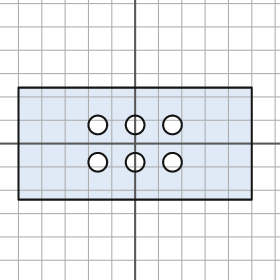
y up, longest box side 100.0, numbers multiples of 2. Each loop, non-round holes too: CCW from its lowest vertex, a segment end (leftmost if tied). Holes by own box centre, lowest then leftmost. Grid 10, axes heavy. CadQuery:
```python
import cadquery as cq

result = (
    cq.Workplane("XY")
    .moveTo(-50.0, -24.0)
    .lineTo(50.0, -24.0)
    .lineTo(50.0, 24.0)
    .lineTo(-50.0, 24.0)
    .close()
    .moveTo(-16.0, -8.0)
    .circle(4.0)
    .moveTo(0.0, -8.0)
    .circle(4.0)
    .moveTo(16.0, -8.0)
    .circle(4.0)
    .moveTo(-16.0, 8.0)
    .circle(4.0)
    .moveTo(0.0, 8.0)
    .circle(4.0)
    .moveTo(16.0, 8.0)
    .circle(4.0)
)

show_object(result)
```